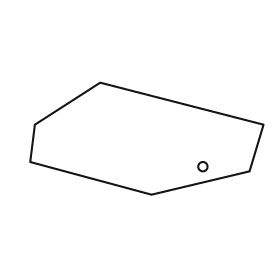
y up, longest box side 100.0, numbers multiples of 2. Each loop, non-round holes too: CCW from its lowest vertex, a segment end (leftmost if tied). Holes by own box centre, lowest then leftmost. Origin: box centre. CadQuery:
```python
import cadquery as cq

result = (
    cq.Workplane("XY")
    .moveTo(2.0, -24.0)
    .lineTo(44.0, -14.0)
    .lineTo(50.0, 6.0)
    .lineTo(-20.0, 24.0)
    .lineTo(-48.0, 6.0)
    .lineTo(-50.0, -10.0)
    .close()
    .moveTo(24.0, -12.0)
    .circle(2.0)
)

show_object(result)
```